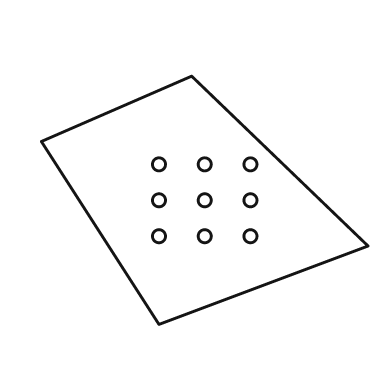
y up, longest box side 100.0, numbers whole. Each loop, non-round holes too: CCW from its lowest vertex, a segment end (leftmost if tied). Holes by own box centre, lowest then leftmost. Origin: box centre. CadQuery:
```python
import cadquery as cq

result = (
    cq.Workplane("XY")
    .moveTo(-14.0, -38.0)
    .lineTo(50.0, -14.0)
    .lineTo(-4.0, 38.0)
    .lineTo(-50.0, 18.0)
    .close()
    .moveTo(-14.0, -11.0)
    .circle(2.0)
    .moveTo(0.0, -11.0)
    .circle(2.0)
    .moveTo(14.0, -11.0)
    .circle(2.0)
    .moveTo(-14.0, 0.0)
    .circle(2.0)
    .moveTo(0.0, 0.0)
    .circle(2.0)
    .moveTo(14.0, 0.0)
    .circle(2.0)
    .moveTo(-14.0, 11.0)
    .circle(2.0)
    .moveTo(0.0, 11.0)
    .circle(2.0)
    .moveTo(14.0, 11.0)
    .circle(2.0)
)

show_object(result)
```